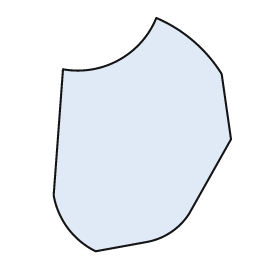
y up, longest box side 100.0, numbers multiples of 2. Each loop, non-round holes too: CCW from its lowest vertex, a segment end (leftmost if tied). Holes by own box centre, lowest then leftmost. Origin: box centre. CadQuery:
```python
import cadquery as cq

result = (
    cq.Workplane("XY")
    .moveTo(-20.0, -50.0)
    .lineTo(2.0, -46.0)
    .threePointArc((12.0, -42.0), (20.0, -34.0))
    .lineTo(38.0, -2.0)
    .lineTo(34.0, 26.0)
    .threePointArc((22.0, 40.0), (6.0, 50.0))
    .threePointArc((-10.0, 32.0), (-34.0, 28.0))
    .lineTo(-38.0, -26.0)
    .threePointArc((-32.0, -40.0), (-20.0, -50.0))
    .close()
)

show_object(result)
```